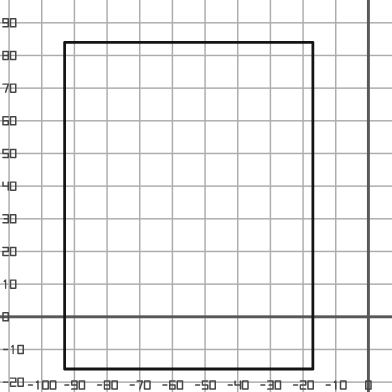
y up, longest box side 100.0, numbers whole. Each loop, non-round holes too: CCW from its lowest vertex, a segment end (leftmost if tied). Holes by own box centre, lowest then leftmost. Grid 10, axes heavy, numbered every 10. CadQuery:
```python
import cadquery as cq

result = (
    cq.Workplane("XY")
    .moveTo(-93.0, -16.0)
    .lineTo(-17.0, -16.0)
    .lineTo(-17.0, 84.0)
    .lineTo(-93.0, 84.0)
    .close()
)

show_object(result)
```